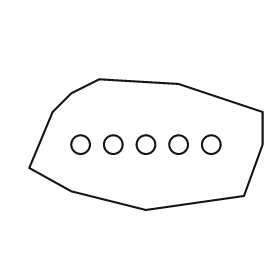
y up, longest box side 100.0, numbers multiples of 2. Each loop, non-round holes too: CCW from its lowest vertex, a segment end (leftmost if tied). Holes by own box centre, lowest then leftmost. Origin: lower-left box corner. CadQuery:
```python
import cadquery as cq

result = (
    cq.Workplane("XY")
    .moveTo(50.0, 0.0)
    .lineTo(92.0, 6.0)
    .lineTo(100.0, 28.0)
    .lineTo(100.0, 42.0)
    .lineTo(64.0, 54.0)
    .lineTo(30.0, 56.0)
    .lineTo(18.0, 50.0)
    .lineTo(10.0, 42.0)
    .lineTo(0.0, 18.0)
    .lineTo(18.0, 8.0)
    .close()
    .moveTo(22.0, 28.0)
    .circle(4.0)
    .moveTo(36.0, 28.0)
    .circle(4.0)
    .moveTo(50.0, 28.0)
    .circle(4.0)
    .moveTo(64.0, 28.0)
    .circle(4.0)
    .moveTo(78.0, 28.0)
    .circle(4.0)
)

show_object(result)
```